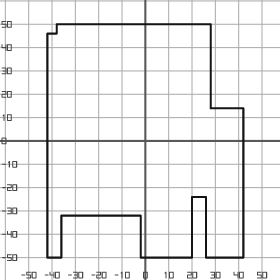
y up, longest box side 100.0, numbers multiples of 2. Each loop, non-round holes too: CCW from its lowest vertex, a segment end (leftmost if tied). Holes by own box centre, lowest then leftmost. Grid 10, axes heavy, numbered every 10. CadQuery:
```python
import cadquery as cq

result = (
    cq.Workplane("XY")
    .moveTo(-42.0, -50.0)
    .lineTo(-36.0, -50.0)
    .lineTo(-36.0, -32.0)
    .lineTo(-2.0, -32.0)
    .lineTo(-2.0, -50.0)
    .lineTo(20.0, -50.0)
    .lineTo(20.0, -24.0)
    .lineTo(26.0, -24.0)
    .lineTo(26.0, -50.0)
    .lineTo(42.0, -50.0)
    .lineTo(42.0, 14.0)
    .lineTo(28.0, 14.0)
    .lineTo(28.0, 50.0)
    .lineTo(-38.0, 50.0)
    .lineTo(-38.0, 46.0)
    .lineTo(-42.0, 46.0)
    .close()
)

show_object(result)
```